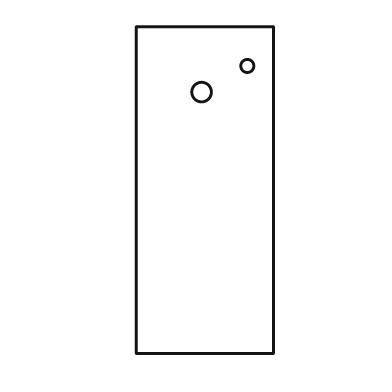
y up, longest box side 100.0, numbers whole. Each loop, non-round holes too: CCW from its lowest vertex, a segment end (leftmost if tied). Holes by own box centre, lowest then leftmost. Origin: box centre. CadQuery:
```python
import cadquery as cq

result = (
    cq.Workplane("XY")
    .moveTo(-21.0, -50.0)
    .lineTo(21.0, -50.0)
    .lineTo(21.0, 50.0)
    .lineTo(-21.0, 50.0)
    .close()
    .moveTo(-1.0, 30.0)
    .circle(3.0)
    .moveTo(13.0, 38.0)
    .circle(2.0)
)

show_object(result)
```